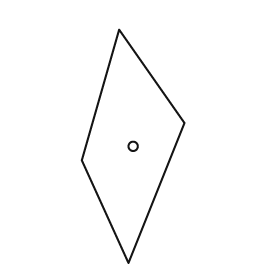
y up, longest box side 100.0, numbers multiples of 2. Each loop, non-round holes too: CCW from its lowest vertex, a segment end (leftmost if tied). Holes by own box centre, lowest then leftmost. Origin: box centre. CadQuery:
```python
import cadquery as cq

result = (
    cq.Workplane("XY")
    .moveTo(-2.0, -50.0)
    .lineTo(22.0, 10.0)
    .lineTo(-6.0, 50.0)
    .lineTo(-22.0, -6.0)
    .close()
    .moveTo(0.0, 0.0)
    .circle(2.0)
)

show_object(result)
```